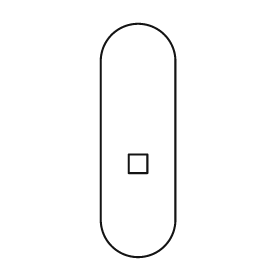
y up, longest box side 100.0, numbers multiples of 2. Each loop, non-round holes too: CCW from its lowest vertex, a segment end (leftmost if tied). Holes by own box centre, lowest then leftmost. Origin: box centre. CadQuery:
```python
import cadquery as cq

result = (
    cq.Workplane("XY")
    .moveTo(-16.0, -34.0)
    .threePointArc((0.0, -50.0), (16.0, -34.0))
    .lineTo(16.0, 34.0)
    .threePointArc((0.0, 50.0), (-16.0, 34.0))
    .close()
    .moveTo(-4.0, -14.0)
    .lineTo(4.0, -14.0)
    .lineTo(4.0, -6.0)
    .lineTo(-4.0, -6.0)
    .close()
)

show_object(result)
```